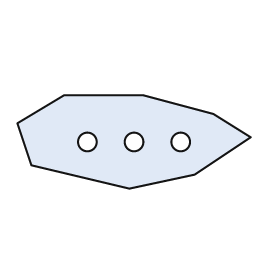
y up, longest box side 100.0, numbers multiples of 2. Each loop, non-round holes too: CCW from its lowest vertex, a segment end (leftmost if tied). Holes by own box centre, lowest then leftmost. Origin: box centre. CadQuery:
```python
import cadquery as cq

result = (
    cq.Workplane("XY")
    .moveTo(-2.0, -20.0)
    .lineTo(26.0, -14.0)
    .lineTo(50.0, 2.0)
    .lineTo(34.0, 12.0)
    .lineTo(4.0, 20.0)
    .lineTo(-30.0, 20.0)
    .lineTo(-50.0, 8.0)
    .lineTo(-44.0, -10.0)
    .close()
    .moveTo(-20.0, 0.0)
    .circle(4.0)
    .moveTo(0.0, 0.0)
    .circle(4.0)
    .moveTo(20.0, 0.0)
    .circle(4.0)
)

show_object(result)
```